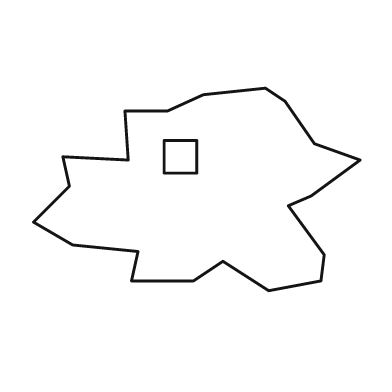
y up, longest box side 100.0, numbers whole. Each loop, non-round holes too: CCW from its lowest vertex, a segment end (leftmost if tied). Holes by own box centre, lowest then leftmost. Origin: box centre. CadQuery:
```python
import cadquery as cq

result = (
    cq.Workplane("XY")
    .moveTo(22.0, -31.0)
    .lineTo(38.0, -28.0)
    .lineTo(39.0, -20.0)
    .lineTo(28.0, -5.0)
    .lineTo(35.0, -2.0)
    .lineTo(50.0, 9.0)
    .lineTo(36.0, 14.0)
    .lineTo(27.0, 27.0)
    .lineTo(21.0, 31.0)
    .lineTo(2.0, 29.0)
    .lineTo(-9.0, 24.0)
    .lineTo(-22.0, 24.0)
    .lineTo(-21.0, 9.0)
    .lineTo(-41.0, 10.0)
    .lineTo(-39.0, 1.0)
    .lineTo(-50.0, -10.0)
    .lineTo(-38.0, -17.0)
    .lineTo(-18.0, -19.0)
    .lineTo(-20.0, -28.0)
    .lineTo(-1.0, -28.0)
    .lineTo(8.0, -22.0)
    .close()
    .moveTo(-10.0, 5.0)
    .lineTo(0.0, 5.0)
    .lineTo(0.0, 15.0)
    .lineTo(-10.0, 15.0)
    .close()
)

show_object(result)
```